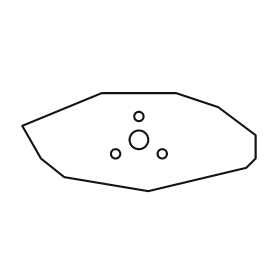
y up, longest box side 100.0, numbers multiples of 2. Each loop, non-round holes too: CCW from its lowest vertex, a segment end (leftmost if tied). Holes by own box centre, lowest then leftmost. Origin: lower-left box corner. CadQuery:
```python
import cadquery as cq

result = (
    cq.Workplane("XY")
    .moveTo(54.0, 0.0)
    .lineTo(96.0, 10.0)
    .lineTo(100.0, 14.0)
    .lineTo(100.0, 24.0)
    .lineTo(84.0, 36.0)
    .lineTo(66.0, 42.0)
    .lineTo(34.0, 42.0)
    .lineTo(0.0, 28.0)
    .lineTo(8.0, 14.0)
    .lineTo(18.0, 6.0)
    .close()
    .moveTo(40.0, 16.0)
    .circle(2.0)
    .moveTo(60.0, 16.0)
    .circle(2.0)
    .moveTo(50.0, 22.0)
    .circle(4.0)
    .moveTo(50.0, 32.0)
    .circle(2.0)
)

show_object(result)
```